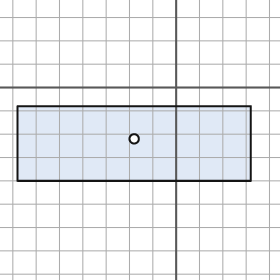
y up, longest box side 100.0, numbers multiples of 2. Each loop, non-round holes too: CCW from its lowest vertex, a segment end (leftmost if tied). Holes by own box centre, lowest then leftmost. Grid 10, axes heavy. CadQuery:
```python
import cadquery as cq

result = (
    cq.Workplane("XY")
    .moveTo(-68.0, -40.0)
    .lineTo(32.0, -40.0)
    .lineTo(32.0, -8.0)
    .lineTo(-68.0, -8.0)
    .close()
    .moveTo(-18.0, -22.0)
    .circle(2.0)
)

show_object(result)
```